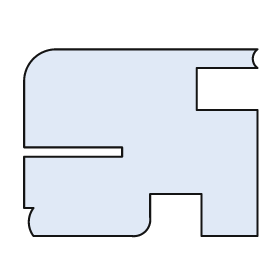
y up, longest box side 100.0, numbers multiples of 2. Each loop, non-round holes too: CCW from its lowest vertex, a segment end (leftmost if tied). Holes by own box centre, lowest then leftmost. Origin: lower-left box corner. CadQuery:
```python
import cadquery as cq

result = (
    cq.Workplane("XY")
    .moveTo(4.0, 0.0)
    .lineTo(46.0, 0.0)
    .threePointArc((52.0, 2.0), (54.0, 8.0))
    .lineTo(54.0, 18.0)
    .lineTo(76.0, 18.0)
    .lineTo(76.0, 0.0)
    .lineTo(100.0, 0.0)
    .lineTo(100.0, 54.0)
    .lineTo(74.0, 54.0)
    .lineTo(74.0, 72.0)
    .lineTo(100.0, 72.0)
    .threePointArc((98.0, 76.0), (100.0, 80.0))
    .lineTo(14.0, 80.0)
    .threePointArc((4.0, 76.0), (0.0, 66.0))
    .lineTo(0.0, 38.0)
    .lineTo(42.0, 38.0)
    .lineTo(42.0, 34.0)
    .lineTo(0.0, 34.0)
    .lineTo(0.0, 12.0)
    .lineTo(4.0, 12.0)
    .threePointArc((2.0, 6.0), (4.0, 0.0))
    .close()
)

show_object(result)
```